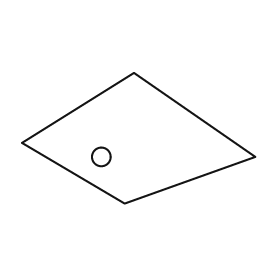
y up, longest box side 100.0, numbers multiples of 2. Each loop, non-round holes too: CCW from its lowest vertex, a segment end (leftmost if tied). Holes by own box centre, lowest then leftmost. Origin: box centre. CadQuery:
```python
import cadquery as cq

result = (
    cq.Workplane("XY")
    .moveTo(-6.0, -28.0)
    .lineTo(50.0, -8.0)
    .lineTo(-2.0, 28.0)
    .lineTo(-50.0, -2.0)
    .close()
    .moveTo(-16.0, -8.0)
    .circle(4.0)
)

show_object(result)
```